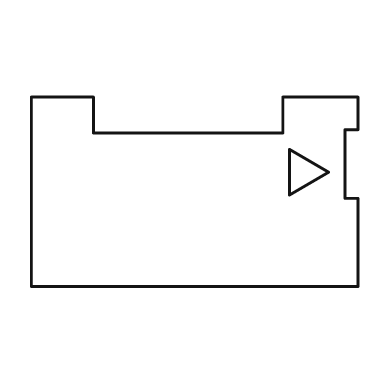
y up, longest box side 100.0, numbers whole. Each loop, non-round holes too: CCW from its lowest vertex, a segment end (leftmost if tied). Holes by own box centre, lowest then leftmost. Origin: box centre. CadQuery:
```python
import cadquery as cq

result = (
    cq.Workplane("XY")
    .moveTo(-50.0, -29.0)
    .lineTo(50.0, -29.0)
    .lineTo(50.0, -2.0)
    .lineTo(46.0, -2.0)
    .lineTo(46.0, 19.0)
    .lineTo(50.0, 19.0)
    .lineTo(50.0, 29.0)
    .lineTo(27.0, 29.0)
    .lineTo(27.0, 18.0)
    .lineTo(-31.0, 18.0)
    .lineTo(-31.0, 29.0)
    .lineTo(-50.0, 29.0)
    .close()
    .moveTo(29.0, -1.0)
    .lineTo(41.0, 6.0)
    .lineTo(29.0, 13.0)
    .close()
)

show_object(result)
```